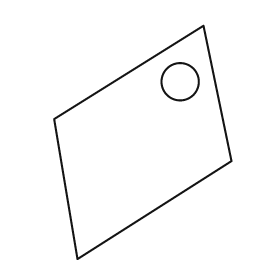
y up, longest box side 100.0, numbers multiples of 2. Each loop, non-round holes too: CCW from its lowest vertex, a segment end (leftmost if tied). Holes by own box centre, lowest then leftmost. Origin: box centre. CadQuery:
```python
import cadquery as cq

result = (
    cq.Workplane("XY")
    .moveTo(-28.0, -50.0)
    .lineTo(38.0, -8.0)
    .lineTo(26.0, 50.0)
    .lineTo(-38.0, 10.0)
    .close()
    .moveTo(16.0, 26.0)
    .circle(8.0)
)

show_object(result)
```